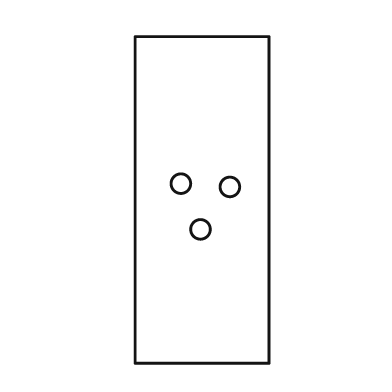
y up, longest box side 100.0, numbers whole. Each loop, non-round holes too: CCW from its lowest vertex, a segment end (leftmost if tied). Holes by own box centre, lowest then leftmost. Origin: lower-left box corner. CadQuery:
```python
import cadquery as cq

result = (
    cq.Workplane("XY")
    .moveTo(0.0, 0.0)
    .lineTo(41.0, 0.0)
    .lineTo(41.0, 100.0)
    .lineTo(0.0, 100.0)
    .close()
    .moveTo(20.0, 41.0)
    .circle(3.0)
    .moveTo(29.0, 54.0)
    .circle(3.0)
    .moveTo(14.0, 55.0)
    .circle(3.0)
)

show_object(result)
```